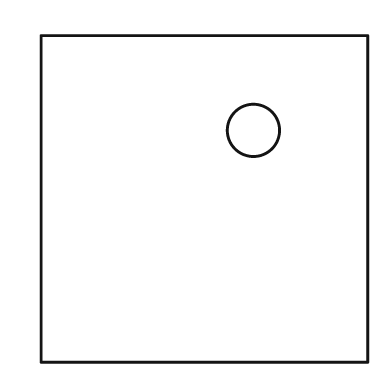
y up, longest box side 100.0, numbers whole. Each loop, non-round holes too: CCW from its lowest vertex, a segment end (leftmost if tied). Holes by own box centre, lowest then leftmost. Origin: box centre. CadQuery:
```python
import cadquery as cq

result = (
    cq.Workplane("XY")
    .moveTo(-50.0, -50.0)
    .lineTo(50.0, -50.0)
    .lineTo(50.0, 50.0)
    .lineTo(-50.0, 50.0)
    .close()
    .moveTo(15.0, 21.0)
    .circle(8.0)
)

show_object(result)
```